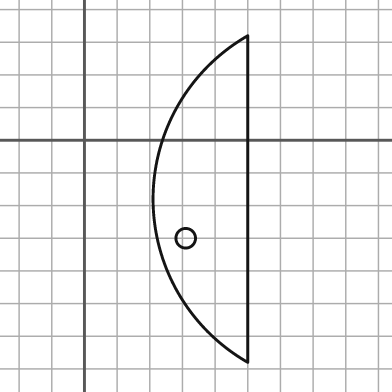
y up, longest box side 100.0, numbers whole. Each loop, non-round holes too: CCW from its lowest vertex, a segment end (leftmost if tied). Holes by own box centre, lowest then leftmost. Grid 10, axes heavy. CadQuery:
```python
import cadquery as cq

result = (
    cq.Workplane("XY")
    .moveTo(50.0, -68.0)
    .lineTo(50.0, 32.0)
    .threePointArc((21.0, -18.0), (50.0, -68.0))
    .close()
    .moveTo(31.0, -30.0)
    .circle(3.0)
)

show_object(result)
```